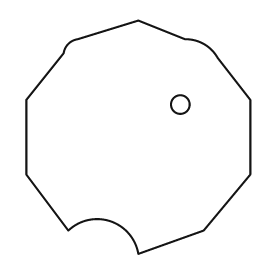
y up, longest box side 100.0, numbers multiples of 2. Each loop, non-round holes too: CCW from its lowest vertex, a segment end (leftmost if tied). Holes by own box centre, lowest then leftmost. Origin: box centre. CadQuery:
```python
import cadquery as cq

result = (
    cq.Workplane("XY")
    .moveTo(0.0, -50.0)
    .lineTo(28.0, -40.0)
    .lineTo(48.0, -16.0)
    .lineTo(48.0, 16.0)
    .lineTo(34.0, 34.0)
    .threePointArc((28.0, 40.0), (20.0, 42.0))
    .lineTo(0.0, 50.0)
    .lineTo(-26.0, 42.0)
    .threePointArc((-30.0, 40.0), (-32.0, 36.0))
    .lineTo(-48.0, 16.0)
    .lineTo(-48.0, -16.0)
    .lineTo(-30.0, -40.0)
    .threePointArc((-12.0, -36.0), (0.0, -50.0))
    .close()
    .moveTo(18.0, 14.0)
    .circle(4.0)
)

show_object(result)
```